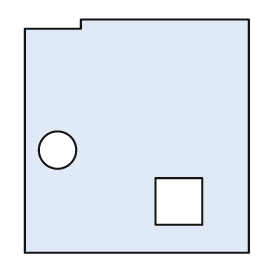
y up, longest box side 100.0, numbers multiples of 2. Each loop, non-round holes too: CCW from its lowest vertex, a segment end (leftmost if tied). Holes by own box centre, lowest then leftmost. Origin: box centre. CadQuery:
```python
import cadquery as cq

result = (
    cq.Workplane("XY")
    .moveTo(-48.0, -50.0)
    .lineTo(48.0, -50.0)
    .lineTo(48.0, 50.0)
    .lineTo(-24.0, 50.0)
    .lineTo(-24.0, 46.0)
    .lineTo(-48.0, 46.0)
    .close()
    .moveTo(8.0, -38.0)
    .lineTo(28.0, -38.0)
    .lineTo(28.0, -18.0)
    .lineTo(8.0, -18.0)
    .close()
    .moveTo(-34.0, -6.0)
    .circle(8.0)
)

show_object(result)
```